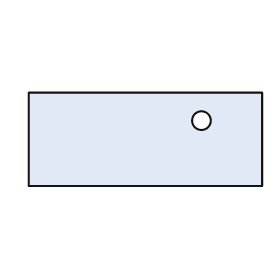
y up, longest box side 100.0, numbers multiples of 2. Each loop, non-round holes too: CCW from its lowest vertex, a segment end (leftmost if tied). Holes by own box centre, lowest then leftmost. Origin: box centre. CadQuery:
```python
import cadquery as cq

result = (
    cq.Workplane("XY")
    .moveTo(-50.0, -20.0)
    .lineTo(50.0, -20.0)
    .lineTo(50.0, 20.0)
    .lineTo(-50.0, 20.0)
    .close()
    .moveTo(24.0, 8.0)
    .circle(4.0)
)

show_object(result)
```